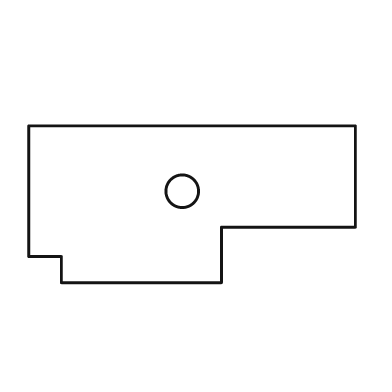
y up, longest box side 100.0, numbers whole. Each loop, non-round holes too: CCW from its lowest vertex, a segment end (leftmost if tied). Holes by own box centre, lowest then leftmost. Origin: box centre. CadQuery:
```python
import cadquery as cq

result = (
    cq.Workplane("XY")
    .moveTo(-40.0, -24.0)
    .lineTo(9.0, -24.0)
    .lineTo(9.0, -7.0)
    .lineTo(50.0, -7.0)
    .lineTo(50.0, 24.0)
    .lineTo(-50.0, 24.0)
    .lineTo(-50.0, -16.0)
    .lineTo(-40.0, -16.0)
    .close()
    .moveTo(-3.0, 4.0)
    .circle(5.0)
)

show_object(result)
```